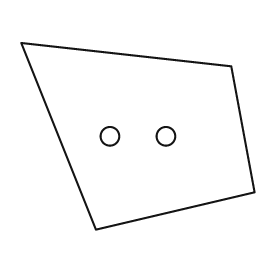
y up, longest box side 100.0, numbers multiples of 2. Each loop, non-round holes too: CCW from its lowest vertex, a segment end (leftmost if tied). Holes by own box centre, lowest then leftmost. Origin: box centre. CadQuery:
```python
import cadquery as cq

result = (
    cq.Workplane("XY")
    .moveTo(-18.0, -40.0)
    .lineTo(50.0, -24.0)
    .lineTo(40.0, 30.0)
    .lineTo(-50.0, 40.0)
    .close()
    .moveTo(-12.0, 0.0)
    .circle(4.0)
    .moveTo(12.0, 0.0)
    .circle(4.0)
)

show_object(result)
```